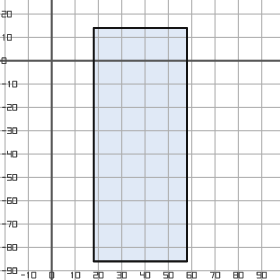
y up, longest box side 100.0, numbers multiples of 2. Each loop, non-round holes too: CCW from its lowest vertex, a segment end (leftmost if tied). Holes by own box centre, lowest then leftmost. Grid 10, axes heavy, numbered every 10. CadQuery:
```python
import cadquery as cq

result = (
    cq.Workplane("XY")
    .moveTo(18.0, -86.0)
    .lineTo(58.0, -86.0)
    .lineTo(58.0, 14.0)
    .lineTo(18.0, 14.0)
    .close()
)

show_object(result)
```